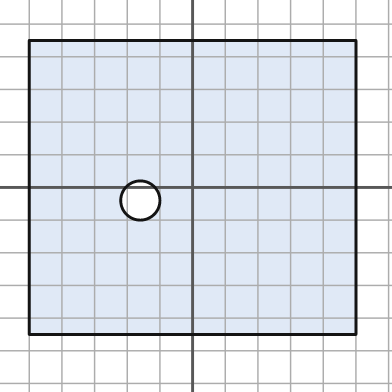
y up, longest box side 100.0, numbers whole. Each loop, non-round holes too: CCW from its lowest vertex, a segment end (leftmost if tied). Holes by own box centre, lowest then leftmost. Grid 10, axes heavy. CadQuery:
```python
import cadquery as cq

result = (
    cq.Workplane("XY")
    .moveTo(-50.0, -45.0)
    .lineTo(50.0, -45.0)
    .lineTo(50.0, 45.0)
    .lineTo(-50.0, 45.0)
    .close()
    .moveTo(-16.0, -4.0)
    .circle(6.0)
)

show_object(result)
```